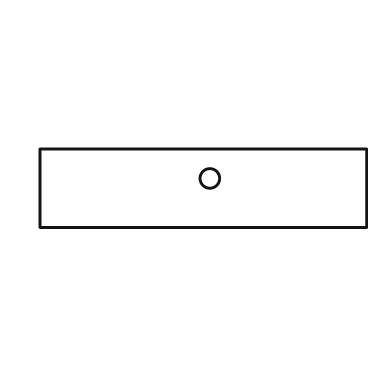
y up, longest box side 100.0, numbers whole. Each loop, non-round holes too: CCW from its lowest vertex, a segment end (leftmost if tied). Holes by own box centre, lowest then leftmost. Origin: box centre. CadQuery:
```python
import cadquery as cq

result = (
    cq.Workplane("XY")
    .moveTo(-50.0, -12.0)
    .lineTo(50.0, -12.0)
    .lineTo(50.0, 12.0)
    .lineTo(-50.0, 12.0)
    .close()
    .moveTo(2.0, 3.0)
    .circle(3.0)
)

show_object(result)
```